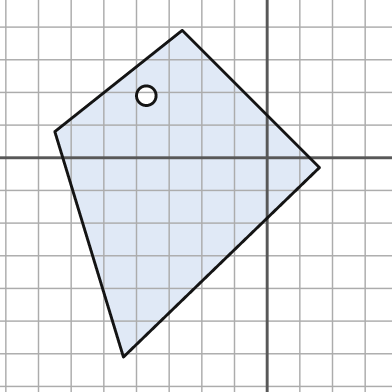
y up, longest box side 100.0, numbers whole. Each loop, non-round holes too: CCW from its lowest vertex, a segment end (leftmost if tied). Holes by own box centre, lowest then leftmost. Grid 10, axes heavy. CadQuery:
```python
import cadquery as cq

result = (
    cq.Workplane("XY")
    .moveTo(-44.0, -61.0)
    .lineTo(16.0, -3.0)
    .lineTo(-26.0, 39.0)
    .lineTo(-65.0, 8.0)
    .close()
    .moveTo(-37.0, 19.0)
    .circle(3.0)
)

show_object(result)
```